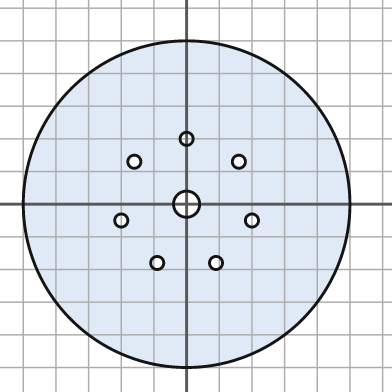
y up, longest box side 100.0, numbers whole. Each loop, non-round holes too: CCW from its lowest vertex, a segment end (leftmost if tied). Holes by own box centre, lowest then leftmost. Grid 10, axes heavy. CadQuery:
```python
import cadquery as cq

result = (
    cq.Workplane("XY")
    .moveTo(0.0, 0.0)
    .circle(50.0)
    .moveTo(-9.0, -18.0)
    .circle(2.0)
    .moveTo(9.0, -18.0)
    .circle(2.0)
    .moveTo(-20.0, -5.0)
    .circle(2.0)
    .moveTo(20.0, -5.0)
    .circle(2.0)
    .moveTo(0.0, 0.0)
    .circle(4.0)
    .moveTo(-16.0, 13.0)
    .circle(2.0)
    .moveTo(16.0, 13.0)
    .circle(2.0)
    .moveTo(0.0, 20.0)
    .circle(2.0)
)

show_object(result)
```